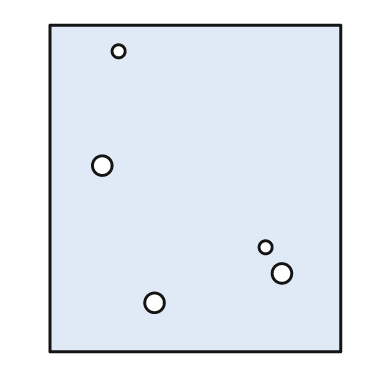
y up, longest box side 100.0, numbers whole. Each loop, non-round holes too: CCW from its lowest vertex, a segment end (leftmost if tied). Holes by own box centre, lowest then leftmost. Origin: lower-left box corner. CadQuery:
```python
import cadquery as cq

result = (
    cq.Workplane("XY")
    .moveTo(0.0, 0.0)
    .lineTo(89.0, 0.0)
    .lineTo(89.0, 100.0)
    .lineTo(0.0, 100.0)
    .close()
    .moveTo(32.0, 15.0)
    .circle(3.0)
    .moveTo(71.0, 24.0)
    .circle(3.0)
    .moveTo(66.0, 32.0)
    .circle(2.0)
    .moveTo(16.0, 57.0)
    .circle(3.0)
    .moveTo(21.0, 92.0)
    .circle(2.0)
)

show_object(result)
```